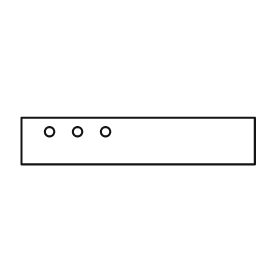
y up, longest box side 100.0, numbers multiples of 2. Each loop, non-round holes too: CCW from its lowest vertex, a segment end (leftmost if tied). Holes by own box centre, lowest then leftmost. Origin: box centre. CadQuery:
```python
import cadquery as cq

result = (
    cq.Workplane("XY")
    .moveTo(-50.0, -10.0)
    .lineTo(50.0, -10.0)
    .lineTo(50.0, 10.0)
    .lineTo(-50.0, 10.0)
    .close()
    .moveTo(-38.0, 4.0)
    .circle(2.0)
    .moveTo(-26.0, 4.0)
    .circle(2.0)
    .moveTo(-14.0, 4.0)
    .circle(2.0)
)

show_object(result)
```